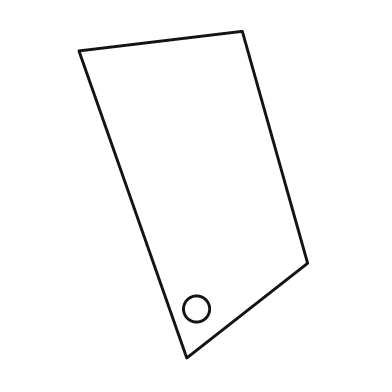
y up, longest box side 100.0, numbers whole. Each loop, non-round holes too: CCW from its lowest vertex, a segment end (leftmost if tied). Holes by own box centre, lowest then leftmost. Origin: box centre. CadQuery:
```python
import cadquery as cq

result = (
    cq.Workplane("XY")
    .moveTo(-2.0, -50.0)
    .lineTo(35.0, -21.0)
    .lineTo(15.0, 50.0)
    .lineTo(-35.0, 44.0)
    .close()
    .moveTo(1.0, -35.0)
    .circle(4.0)
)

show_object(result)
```